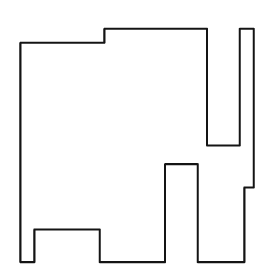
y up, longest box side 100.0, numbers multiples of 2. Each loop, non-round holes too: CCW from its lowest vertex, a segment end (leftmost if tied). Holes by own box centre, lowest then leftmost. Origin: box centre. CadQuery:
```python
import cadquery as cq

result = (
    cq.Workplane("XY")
    .moveTo(-50.0, -50.0)
    .lineTo(-44.0, -50.0)
    .lineTo(-44.0, -36.0)
    .lineTo(-16.0, -36.0)
    .lineTo(-16.0, -50.0)
    .lineTo(12.0, -50.0)
    .lineTo(12.0, -8.0)
    .lineTo(26.0, -8.0)
    .lineTo(26.0, -50.0)
    .lineTo(46.0, -50.0)
    .lineTo(46.0, -18.0)
    .lineTo(50.0, -18.0)
    .lineTo(50.0, 50.0)
    .lineTo(44.0, 50.0)
    .lineTo(44.0, 0.0)
    .lineTo(30.0, 0.0)
    .lineTo(30.0, 50.0)
    .lineTo(-14.0, 50.0)
    .lineTo(-14.0, 44.0)
    .lineTo(-50.0, 44.0)
    .close()
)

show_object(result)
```